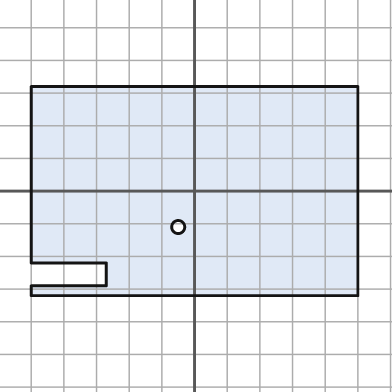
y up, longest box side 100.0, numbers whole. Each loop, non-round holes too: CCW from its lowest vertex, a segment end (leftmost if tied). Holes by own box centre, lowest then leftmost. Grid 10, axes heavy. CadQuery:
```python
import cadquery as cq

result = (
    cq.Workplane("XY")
    .moveTo(-50.0, -32.0)
    .lineTo(50.0, -32.0)
    .lineTo(50.0, 32.0)
    .lineTo(-50.0, 32.0)
    .lineTo(-50.0, -22.0)
    .lineTo(-27.0, -22.0)
    .lineTo(-27.0, -29.0)
    .lineTo(-50.0, -29.0)
    .close()
    .moveTo(-5.0, -11.0)
    .circle(2.0)
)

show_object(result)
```